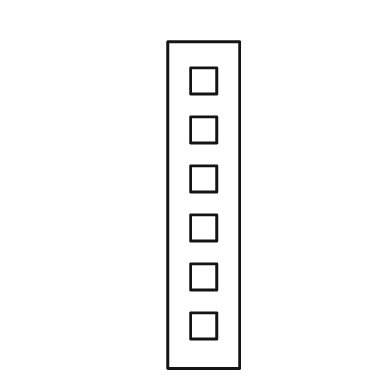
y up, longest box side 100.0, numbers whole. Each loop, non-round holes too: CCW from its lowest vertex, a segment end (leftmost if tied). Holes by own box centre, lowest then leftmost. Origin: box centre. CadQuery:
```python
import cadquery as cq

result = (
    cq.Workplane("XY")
    .moveTo(-11.0, -50.0)
    .lineTo(11.0, -50.0)
    .lineTo(11.0, 50.0)
    .lineTo(-11.0, 50.0)
    .close()
    .moveTo(-4.0, -41.0)
    .lineTo(4.0, -41.0)
    .lineTo(4.0, -33.0)
    .lineTo(-4.0, -33.0)
    .close()
    .moveTo(-4.0, -26.0)
    .lineTo(4.0, -26.0)
    .lineTo(4.0, -18.0)
    .lineTo(-4.0, -18.0)
    .close()
    .moveTo(-4.0, -11.0)
    .lineTo(4.0, -11.0)
    .lineTo(4.0, -3.0)
    .lineTo(-4.0, -3.0)
    .close()
    .moveTo(-4.0, 4.0)
    .lineTo(4.0, 4.0)
    .lineTo(4.0, 12.0)
    .lineTo(-4.0, 12.0)
    .close()
    .moveTo(-4.0, 19.0)
    .lineTo(4.0, 19.0)
    .lineTo(4.0, 27.0)
    .lineTo(-4.0, 27.0)
    .close()
    .moveTo(-4.0, 34.0)
    .lineTo(4.0, 34.0)
    .lineTo(4.0, 42.0)
    .lineTo(-4.0, 42.0)
    .close()
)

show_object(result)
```